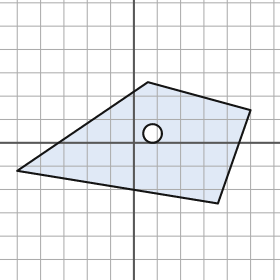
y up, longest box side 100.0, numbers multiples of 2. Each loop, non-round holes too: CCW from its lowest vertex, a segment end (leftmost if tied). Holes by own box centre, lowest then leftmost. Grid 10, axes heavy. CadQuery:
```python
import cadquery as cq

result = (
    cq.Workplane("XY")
    .moveTo(36.0, -26.0)
    .lineTo(50.0, 14.0)
    .lineTo(6.0, 26.0)
    .lineTo(-50.0, -12.0)
    .close()
    .moveTo(8.0, 4.0)
    .circle(4.0)
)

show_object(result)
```